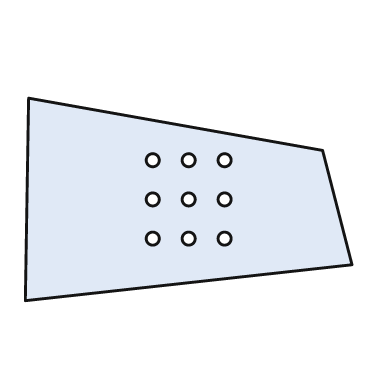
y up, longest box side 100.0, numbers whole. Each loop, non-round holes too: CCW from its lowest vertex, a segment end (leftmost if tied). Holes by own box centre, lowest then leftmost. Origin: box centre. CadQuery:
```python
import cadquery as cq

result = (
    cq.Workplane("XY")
    .moveTo(-50.0, -31.0)
    .lineTo(50.0, -20.0)
    .lineTo(41.0, 15.0)
    .lineTo(-49.0, 31.0)
    .close()
    .moveTo(-11.0, -12.0)
    .circle(2.0)
    .moveTo(0.0, -12.0)
    .circle(2.0)
    .moveTo(11.0, -12.0)
    .circle(2.0)
    .moveTo(-11.0, 0.0)
    .circle(2.0)
    .moveTo(0.0, 0.0)
    .circle(2.0)
    .moveTo(11.0, 0.0)
    .circle(2.0)
    .moveTo(-11.0, 12.0)
    .circle(2.0)
    .moveTo(0.0, 12.0)
    .circle(2.0)
    .moveTo(11.0, 12.0)
    .circle(2.0)
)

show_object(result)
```